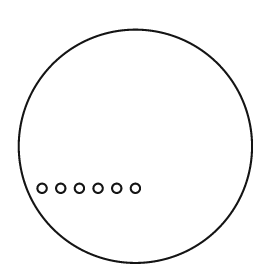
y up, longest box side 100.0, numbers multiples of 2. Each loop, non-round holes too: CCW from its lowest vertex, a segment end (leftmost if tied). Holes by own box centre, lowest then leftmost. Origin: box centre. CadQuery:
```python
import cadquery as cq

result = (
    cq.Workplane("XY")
    .moveTo(0.0, 0.0)
    .circle(50.0)
    .moveTo(-40.0, -18.0)
    .circle(2.0)
    .moveTo(-32.0, -18.0)
    .circle(2.0)
    .moveTo(-24.0, -18.0)
    .circle(2.0)
    .moveTo(-16.0, -18.0)
    .circle(2.0)
    .moveTo(-8.0, -18.0)
    .circle(2.0)
    .moveTo(0.0, -18.0)
    .circle(2.0)
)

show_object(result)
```